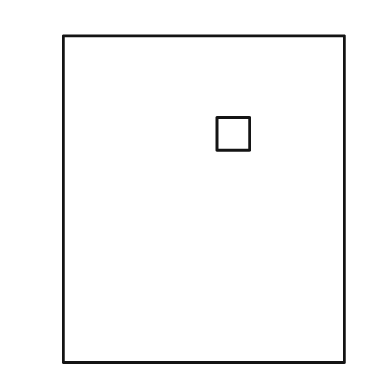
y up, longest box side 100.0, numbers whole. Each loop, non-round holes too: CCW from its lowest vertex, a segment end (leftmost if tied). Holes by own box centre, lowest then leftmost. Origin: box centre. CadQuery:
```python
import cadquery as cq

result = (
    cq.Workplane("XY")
    .moveTo(-43.0, -50.0)
    .lineTo(43.0, -50.0)
    .lineTo(43.0, 50.0)
    .lineTo(-43.0, 50.0)
    .close()
    .moveTo(4.0, 15.0)
    .lineTo(14.0, 15.0)
    .lineTo(14.0, 25.0)
    .lineTo(4.0, 25.0)
    .close()
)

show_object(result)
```